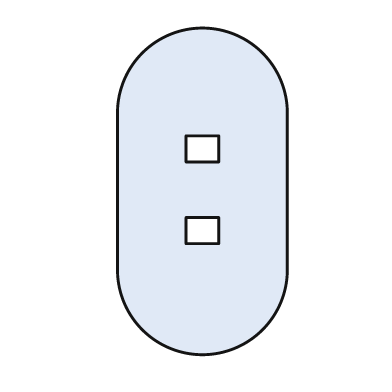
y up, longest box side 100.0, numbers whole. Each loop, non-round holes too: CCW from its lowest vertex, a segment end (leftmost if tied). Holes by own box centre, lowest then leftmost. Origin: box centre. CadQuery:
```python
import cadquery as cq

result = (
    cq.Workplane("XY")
    .moveTo(-26.0, -24.0)
    .threePointArc((0.0, -50.0), (26.0, -24.0))
    .lineTo(26.0, 24.0)
    .threePointArc((0.0, 50.0), (-26.0, 24.0))
    .close()
    .moveTo(-5.0, -16.0)
    .lineTo(5.0, -16.0)
    .lineTo(5.0, -8.0)
    .lineTo(-5.0, -8.0)
    .close()
    .moveTo(-5.0, 9.0)
    .lineTo(5.0, 9.0)
    .lineTo(5.0, 17.0)
    .lineTo(-5.0, 17.0)
    .close()
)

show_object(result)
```